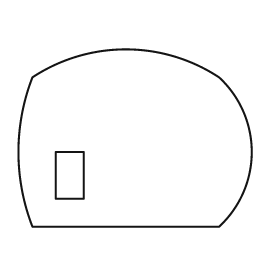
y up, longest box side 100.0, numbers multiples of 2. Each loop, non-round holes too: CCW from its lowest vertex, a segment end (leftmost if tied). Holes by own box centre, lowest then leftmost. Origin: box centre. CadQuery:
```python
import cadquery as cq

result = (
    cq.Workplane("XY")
    .moveTo(-44.0, -38.0)
    .lineTo(36.0, -38.0)
    .threePointArc((50.0, -6.0), (36.0, 26.0))
    .threePointArc((-4.0, 38.0), (-44.0, 26.0))
    .threePointArc((-50.0, -6.0), (-44.0, -38.0))
    .close()
    .moveTo(-34.0, -26.0)
    .lineTo(-22.0, -26.0)
    .lineTo(-22.0, -6.0)
    .lineTo(-34.0, -6.0)
    .close()
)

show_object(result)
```